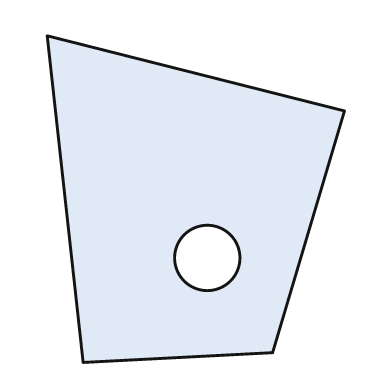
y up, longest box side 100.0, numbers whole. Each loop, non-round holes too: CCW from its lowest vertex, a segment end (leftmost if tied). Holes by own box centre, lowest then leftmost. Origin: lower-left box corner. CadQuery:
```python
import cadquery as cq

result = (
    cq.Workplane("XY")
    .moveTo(11.0, 0.0)
    .lineTo(69.0, 3.0)
    .lineTo(91.0, 77.0)
    .lineTo(0.0, 100.0)
    .close()
    .moveTo(49.0, 32.0)
    .circle(10.0)
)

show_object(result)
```